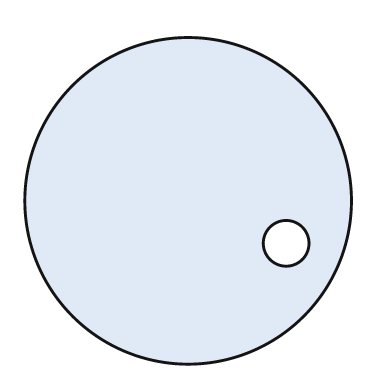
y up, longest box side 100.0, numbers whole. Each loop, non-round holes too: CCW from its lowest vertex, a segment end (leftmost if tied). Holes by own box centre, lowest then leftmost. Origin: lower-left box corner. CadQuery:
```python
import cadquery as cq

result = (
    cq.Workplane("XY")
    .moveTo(50.0, 50.0)
    .circle(50.0)
    .moveTo(80.0, 37.0)
    .circle(7.0)
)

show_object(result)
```